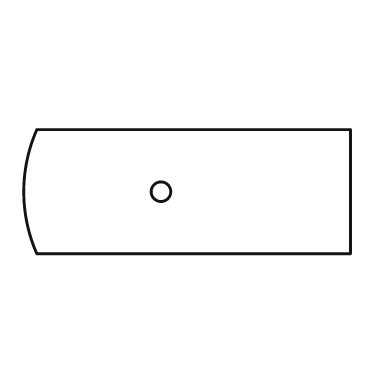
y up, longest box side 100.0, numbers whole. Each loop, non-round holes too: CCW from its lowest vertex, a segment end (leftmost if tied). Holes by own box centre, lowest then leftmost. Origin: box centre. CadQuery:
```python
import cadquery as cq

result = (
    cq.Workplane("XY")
    .moveTo(-46.0, -19.0)
    .lineTo(50.0, -19.0)
    .lineTo(50.0, 19.0)
    .lineTo(-46.0, 19.0)
    .threePointArc((-50.0, 0.0), (-46.0, -19.0))
    .close()
    .moveTo(-8.0, 0.0)
    .circle(3.0)
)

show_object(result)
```